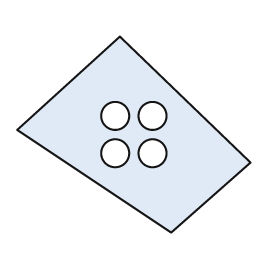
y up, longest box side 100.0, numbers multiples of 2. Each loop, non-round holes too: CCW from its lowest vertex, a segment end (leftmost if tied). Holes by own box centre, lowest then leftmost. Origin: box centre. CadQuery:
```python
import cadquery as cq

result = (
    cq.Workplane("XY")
    .moveTo(16.0, -42.0)
    .lineTo(50.0, -12.0)
    .lineTo(-6.0, 42.0)
    .lineTo(-50.0, 2.0)
    .close()
    .moveTo(-8.0, -8.0)
    .circle(6.0)
    .moveTo(8.0, -8.0)
    .circle(6.0)
    .moveTo(-8.0, 8.0)
    .circle(6.0)
    .moveTo(8.0, 8.0)
    .circle(6.0)
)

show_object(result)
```